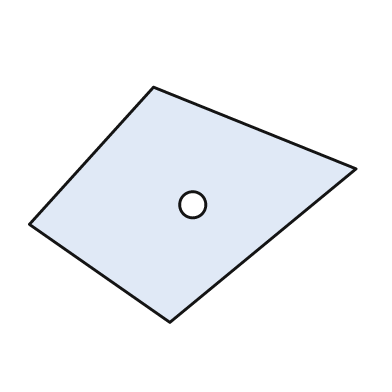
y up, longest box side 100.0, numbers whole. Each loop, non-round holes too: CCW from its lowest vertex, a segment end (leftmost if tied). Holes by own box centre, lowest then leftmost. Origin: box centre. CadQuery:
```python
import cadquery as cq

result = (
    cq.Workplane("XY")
    .moveTo(-7.0, -36.0)
    .lineTo(50.0, 11.0)
    .lineTo(-12.0, 36.0)
    .lineTo(-50.0, -6.0)
    .close()
    .moveTo(0.0, 0.0)
    .circle(4.0)
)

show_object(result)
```